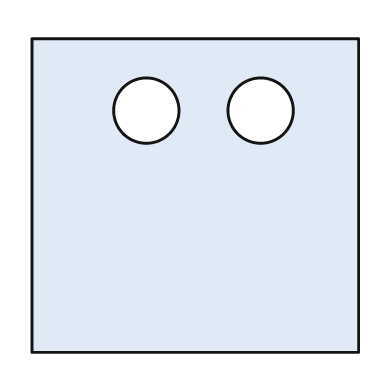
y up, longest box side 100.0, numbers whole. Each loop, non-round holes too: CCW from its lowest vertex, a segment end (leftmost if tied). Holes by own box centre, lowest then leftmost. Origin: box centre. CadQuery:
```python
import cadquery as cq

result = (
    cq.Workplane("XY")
    .moveTo(-50.0, -48.0)
    .lineTo(50.0, -48.0)
    .lineTo(50.0, 48.0)
    .lineTo(-50.0, 48.0)
    .close()
    .moveTo(-15.0, 26.0)
    .circle(10.0)
    .moveTo(20.0, 26.0)
    .circle(10.0)
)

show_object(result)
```